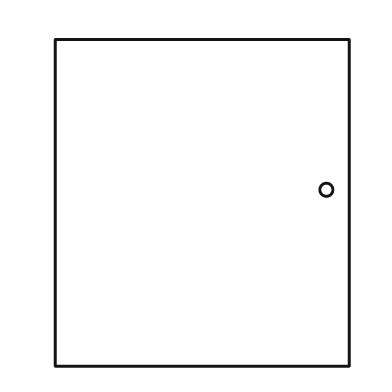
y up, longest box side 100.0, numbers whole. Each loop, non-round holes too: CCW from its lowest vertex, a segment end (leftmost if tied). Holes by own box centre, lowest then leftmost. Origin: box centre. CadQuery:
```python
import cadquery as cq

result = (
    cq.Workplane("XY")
    .moveTo(-45.0, -50.0)
    .lineTo(45.0, -50.0)
    .lineTo(45.0, 50.0)
    .lineTo(-45.0, 50.0)
    .close()
    .moveTo(38.0, 4.0)
    .circle(2.0)
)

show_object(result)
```